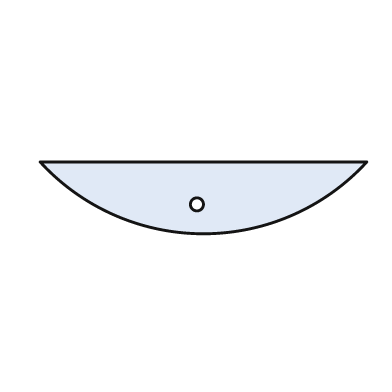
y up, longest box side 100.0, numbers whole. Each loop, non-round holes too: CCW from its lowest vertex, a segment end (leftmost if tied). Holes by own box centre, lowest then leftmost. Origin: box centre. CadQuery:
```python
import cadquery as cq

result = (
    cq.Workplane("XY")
    .moveTo(-50.0, 11.0)
    .threePointArc((0.0, -11.0), (50.0, 11.0))
    .close()
    .moveTo(-2.0, -2.0)
    .circle(2.0)
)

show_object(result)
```